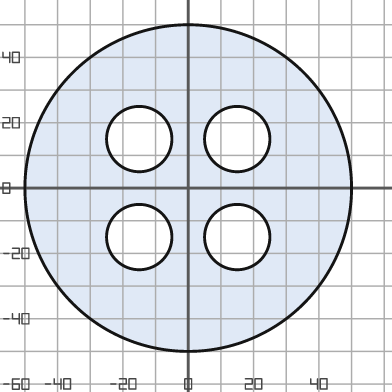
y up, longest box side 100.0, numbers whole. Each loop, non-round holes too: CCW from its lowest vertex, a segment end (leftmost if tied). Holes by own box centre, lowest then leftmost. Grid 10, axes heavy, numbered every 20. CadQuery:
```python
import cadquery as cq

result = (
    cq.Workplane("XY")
    .moveTo(0.0, 0.0)
    .circle(50.0)
    .moveTo(-15.0, -15.0)
    .circle(10.0)
    .moveTo(15.0, -15.0)
    .circle(10.0)
    .moveTo(-15.0, 15.0)
    .circle(10.0)
    .moveTo(15.0, 15.0)
    .circle(10.0)
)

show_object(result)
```